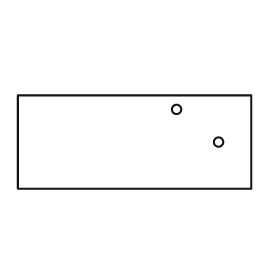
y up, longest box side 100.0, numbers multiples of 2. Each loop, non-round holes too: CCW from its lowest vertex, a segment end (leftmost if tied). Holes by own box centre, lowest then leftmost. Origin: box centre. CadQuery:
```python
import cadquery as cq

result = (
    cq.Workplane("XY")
    .moveTo(-50.0, -20.0)
    .lineTo(50.0, -20.0)
    .lineTo(50.0, 20.0)
    .lineTo(-50.0, 20.0)
    .close()
    .moveTo(36.0, 0.0)
    .circle(2.0)
    .moveTo(18.0, 14.0)
    .circle(2.0)
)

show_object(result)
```